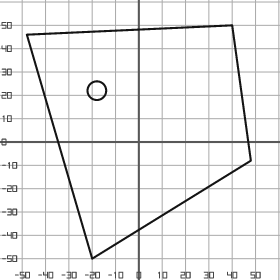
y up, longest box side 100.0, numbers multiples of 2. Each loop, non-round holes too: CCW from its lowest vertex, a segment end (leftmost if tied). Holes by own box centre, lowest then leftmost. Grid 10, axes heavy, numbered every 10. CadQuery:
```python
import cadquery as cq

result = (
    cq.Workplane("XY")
    .moveTo(-20.0, -50.0)
    .lineTo(48.0, -8.0)
    .lineTo(40.0, 50.0)
    .lineTo(-48.0, 46.0)
    .close()
    .moveTo(-18.0, 22.0)
    .circle(4.0)
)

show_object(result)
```